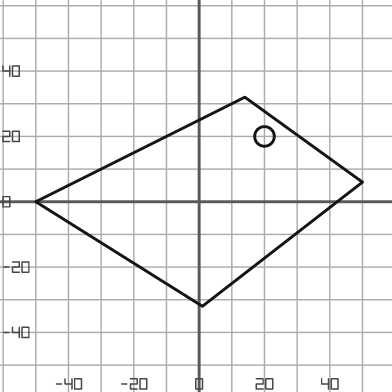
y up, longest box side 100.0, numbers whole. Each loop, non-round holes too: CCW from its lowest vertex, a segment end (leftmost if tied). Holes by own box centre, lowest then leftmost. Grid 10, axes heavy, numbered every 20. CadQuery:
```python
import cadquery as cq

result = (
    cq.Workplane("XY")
    .moveTo(1.0, -32.0)
    .lineTo(50.0, 6.0)
    .lineTo(14.0, 32.0)
    .lineTo(-50.0, 0.0)
    .close()
    .moveTo(20.0, 20.0)
    .circle(3.0)
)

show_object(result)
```